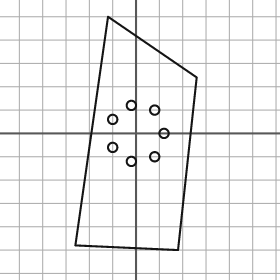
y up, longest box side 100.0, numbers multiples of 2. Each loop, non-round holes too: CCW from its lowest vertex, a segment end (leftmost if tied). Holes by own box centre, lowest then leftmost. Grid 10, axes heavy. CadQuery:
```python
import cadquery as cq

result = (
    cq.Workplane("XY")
    .moveTo(18.0, -50.0)
    .lineTo(26.0, 24.0)
    .lineTo(-12.0, 50.0)
    .lineTo(-26.0, -48.0)
    .close()
    .moveTo(-2.0, -12.0)
    .circle(2.0)
    .moveTo(8.0, -10.0)
    .circle(2.0)
    .moveTo(-10.0, -6.0)
    .circle(2.0)
    .moveTo(12.0, 0.0)
    .circle(2.0)
    .moveTo(-10.0, 6.0)
    .circle(2.0)
    .moveTo(8.0, 10.0)
    .circle(2.0)
    .moveTo(-2.0, 12.0)
    .circle(2.0)
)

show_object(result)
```